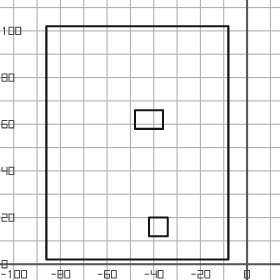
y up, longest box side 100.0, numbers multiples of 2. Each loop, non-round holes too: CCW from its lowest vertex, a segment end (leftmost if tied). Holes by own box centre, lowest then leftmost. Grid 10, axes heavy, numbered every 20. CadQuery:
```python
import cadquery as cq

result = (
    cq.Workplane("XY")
    .moveTo(-86.0, 2.0)
    .lineTo(-8.0, 2.0)
    .lineTo(-8.0, 102.0)
    .lineTo(-86.0, 102.0)
    .close()
    .moveTo(-42.0, 12.0)
    .lineTo(-34.0, 12.0)
    .lineTo(-34.0, 20.0)
    .lineTo(-42.0, 20.0)
    .close()
    .moveTo(-48.0, 58.0)
    .lineTo(-36.0, 58.0)
    .lineTo(-36.0, 66.0)
    .lineTo(-48.0, 66.0)
    .close()
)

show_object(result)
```